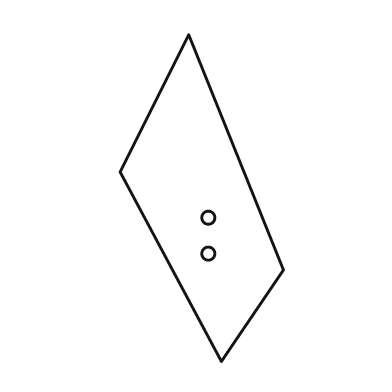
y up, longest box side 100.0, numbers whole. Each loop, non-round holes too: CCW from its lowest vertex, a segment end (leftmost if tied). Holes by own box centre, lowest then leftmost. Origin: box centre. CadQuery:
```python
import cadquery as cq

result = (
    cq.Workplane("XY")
    .moveTo(6.0, -50.0)
    .lineTo(25.0, -22.0)
    .lineTo(-4.0, 50.0)
    .lineTo(-25.0, 8.0)
    .close()
    .moveTo(2.0, -17.0)
    .circle(2.0)
    .moveTo(2.0, -6.0)
    .circle(2.0)
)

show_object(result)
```